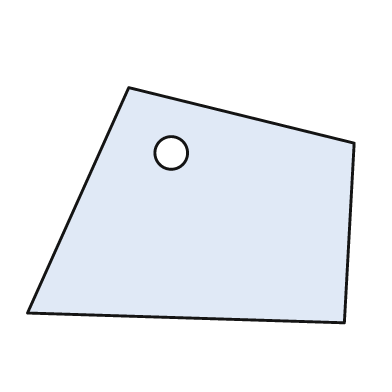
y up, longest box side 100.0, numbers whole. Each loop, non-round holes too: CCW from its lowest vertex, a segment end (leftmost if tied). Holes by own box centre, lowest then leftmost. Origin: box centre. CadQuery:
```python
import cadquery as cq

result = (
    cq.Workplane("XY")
    .moveTo(47.0, -36.0)
    .lineTo(50.0, 19.0)
    .lineTo(-19.0, 36.0)
    .lineTo(-50.0, -33.0)
    .close()
    .moveTo(-6.0, 16.0)
    .circle(5.0)
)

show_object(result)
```